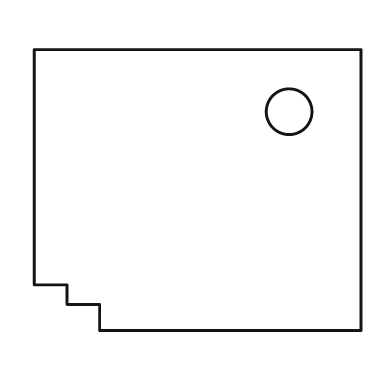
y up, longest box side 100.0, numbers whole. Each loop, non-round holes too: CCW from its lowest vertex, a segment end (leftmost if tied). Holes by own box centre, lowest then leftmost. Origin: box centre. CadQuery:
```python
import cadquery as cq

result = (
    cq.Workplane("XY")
    .moveTo(-30.0, -43.0)
    .lineTo(50.0, -43.0)
    .lineTo(50.0, 43.0)
    .lineTo(-50.0, 43.0)
    .lineTo(-50.0, -29.0)
    .lineTo(-40.0, -29.0)
    .lineTo(-40.0, -35.0)
    .lineTo(-30.0, -35.0)
    .close()
    .moveTo(28.0, 24.0)
    .circle(7.0)
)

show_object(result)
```